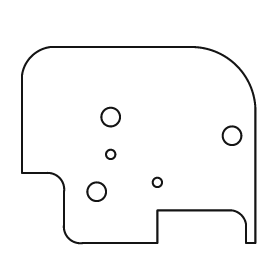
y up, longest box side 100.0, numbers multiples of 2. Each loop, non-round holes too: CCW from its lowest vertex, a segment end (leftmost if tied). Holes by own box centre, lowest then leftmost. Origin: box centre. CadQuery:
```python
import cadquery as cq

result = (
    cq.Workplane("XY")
    .moveTo(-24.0, -42.0)
    .lineTo(8.0, -42.0)
    .lineTo(8.0, -28.0)
    .lineTo(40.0, -28.0)
    .threePointArc((44.0, -30.0), (46.0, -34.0))
    .lineTo(46.0, -42.0)
    .lineTo(50.0, -42.0)
    .lineTo(50.0, 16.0)
    .threePointArc((42.0, 34.0), (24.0, 42.0))
    .lineTo(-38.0, 42.0)
    .threePointArc((-46.0, 38.0), (-50.0, 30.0))
    .lineTo(-50.0, -12.0)
    .lineTo(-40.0, -12.0)
    .threePointArc((-34.0, -14.0), (-32.0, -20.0))
    .lineTo(-32.0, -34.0)
    .threePointArc((-30.0, -40.0), (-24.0, -42.0))
    .close()
    .moveTo(-18.0, -20.0)
    .circle(4.0)
    .moveTo(8.0, -16.0)
    .circle(2.0)
    .moveTo(-12.0, -4.0)
    .circle(2.0)
    .moveTo(40.0, 4.0)
    .circle(4.0)
    .moveTo(-12.0, 12.0)
    .circle(4.0)
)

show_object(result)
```